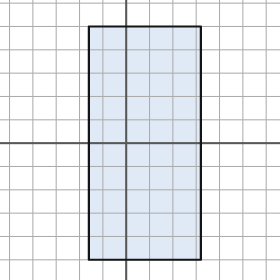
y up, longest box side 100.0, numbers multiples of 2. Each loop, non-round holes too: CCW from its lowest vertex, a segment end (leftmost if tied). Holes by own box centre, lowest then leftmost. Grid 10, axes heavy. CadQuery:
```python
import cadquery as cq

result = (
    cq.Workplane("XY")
    .moveTo(-16.0, -50.0)
    .lineTo(32.0, -50.0)
    .lineTo(32.0, 50.0)
    .lineTo(-16.0, 50.0)
    .close()
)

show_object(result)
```